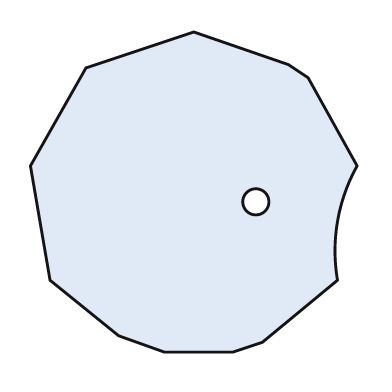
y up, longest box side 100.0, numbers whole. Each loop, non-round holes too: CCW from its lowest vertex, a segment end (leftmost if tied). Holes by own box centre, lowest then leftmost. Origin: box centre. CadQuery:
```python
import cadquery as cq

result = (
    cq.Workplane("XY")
    .moveTo(-9.0, -49.0)
    .lineTo(12.0, -49.0)
    .lineTo(21.0, -46.0)
    .lineTo(44.0, -27.0)
    .threePointArc((44.0, -9.0), (50.0, 8.0))
    .lineTo(35.0, 35.0)
    .lineTo(29.0, 39.0)
    .lineTo(0.0, 49.0)
    .lineTo(-33.0, 38.0)
    .lineTo(-50.0, 8.0)
    .lineTo(-44.0, -27.0)
    .lineTo(-23.0, -44.0)
    .close()
    .moveTo(19.0, -3.0)
    .circle(4.0)
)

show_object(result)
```